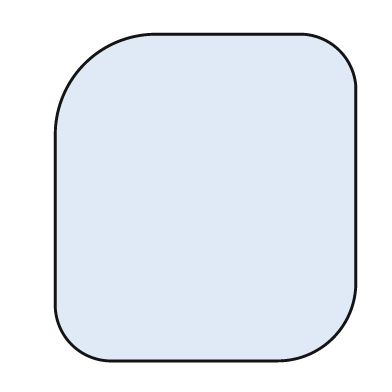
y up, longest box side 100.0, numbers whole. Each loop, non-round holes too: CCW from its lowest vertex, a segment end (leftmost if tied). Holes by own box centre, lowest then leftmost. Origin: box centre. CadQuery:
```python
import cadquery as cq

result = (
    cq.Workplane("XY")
    .moveTo(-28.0, -50.0)
    .lineTo(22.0, -50.0)
    .threePointArc((39.0, -43.0), (46.0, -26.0))
    .lineTo(46.0, 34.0)
    .threePointArc((41.0, 45.0), (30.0, 50.0))
    .lineTo(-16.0, 50.0)
    .threePointArc((-37.0, 41.0), (-46.0, 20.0))
    .lineTo(-46.0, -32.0)
    .threePointArc((-41.0, -45.0), (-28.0, -50.0))
    .close()
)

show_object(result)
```